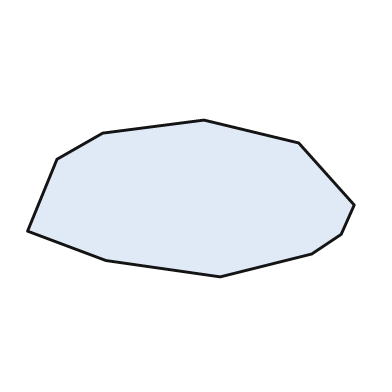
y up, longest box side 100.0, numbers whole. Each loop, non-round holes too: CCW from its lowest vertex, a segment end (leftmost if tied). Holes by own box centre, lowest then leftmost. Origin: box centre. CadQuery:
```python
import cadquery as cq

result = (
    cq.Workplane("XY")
    .moveTo(9.0, -24.0)
    .lineTo(37.0, -17.0)
    .lineTo(46.0, -11.0)
    .lineTo(50.0, -2.0)
    .lineTo(33.0, 17.0)
    .lineTo(4.0, 24.0)
    .lineTo(-27.0, 20.0)
    .lineTo(-41.0, 12.0)
    .lineTo(-50.0, -10.0)
    .lineTo(-26.0, -19.0)
    .close()
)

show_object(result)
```